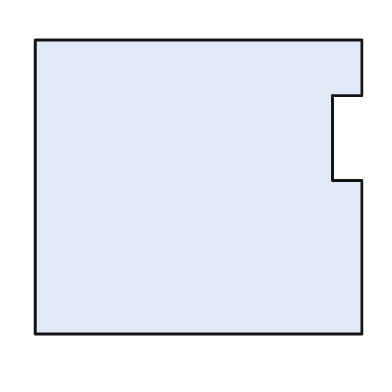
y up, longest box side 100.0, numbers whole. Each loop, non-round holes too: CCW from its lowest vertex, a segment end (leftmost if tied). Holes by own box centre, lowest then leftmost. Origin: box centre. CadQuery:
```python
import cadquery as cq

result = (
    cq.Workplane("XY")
    .moveTo(-50.0, -45.0)
    .lineTo(50.0, -45.0)
    .lineTo(50.0, 2.0)
    .lineTo(41.0, 2.0)
    .lineTo(41.0, 28.0)
    .lineTo(50.0, 28.0)
    .lineTo(50.0, 45.0)
    .lineTo(-50.0, 45.0)
    .close()
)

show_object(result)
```